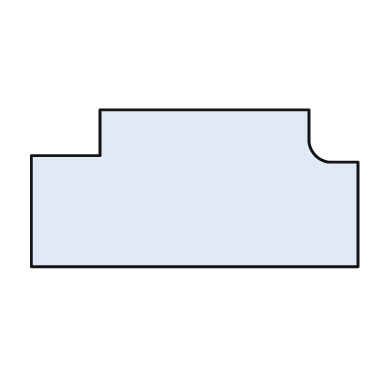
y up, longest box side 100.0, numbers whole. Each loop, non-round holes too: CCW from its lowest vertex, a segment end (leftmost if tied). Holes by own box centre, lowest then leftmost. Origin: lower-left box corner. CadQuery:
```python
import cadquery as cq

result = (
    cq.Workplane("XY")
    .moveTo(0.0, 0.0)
    .lineTo(100.0, 0.0)
    .lineTo(100.0, 32.0)
    .lineTo(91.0, 32.0)
    .threePointArc((87.0, 34.0), (85.0, 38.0))
    .lineTo(85.0, 48.0)
    .lineTo(21.0, 48.0)
    .lineTo(21.0, 34.0)
    .lineTo(0.0, 34.0)
    .close()
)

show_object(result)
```